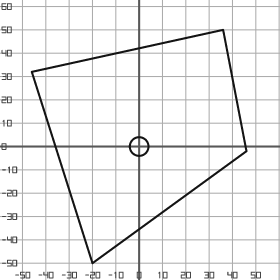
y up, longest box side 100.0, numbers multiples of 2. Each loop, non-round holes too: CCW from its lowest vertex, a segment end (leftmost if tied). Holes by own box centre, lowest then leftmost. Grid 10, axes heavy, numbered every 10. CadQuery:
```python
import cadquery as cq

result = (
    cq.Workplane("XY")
    .moveTo(-20.0, -50.0)
    .lineTo(46.0, -2.0)
    .lineTo(36.0, 50.0)
    .lineTo(-46.0, 32.0)
    .close()
    .moveTo(0.0, 0.0)
    .circle(4.0)
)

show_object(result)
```